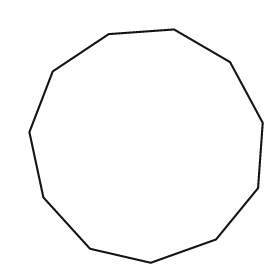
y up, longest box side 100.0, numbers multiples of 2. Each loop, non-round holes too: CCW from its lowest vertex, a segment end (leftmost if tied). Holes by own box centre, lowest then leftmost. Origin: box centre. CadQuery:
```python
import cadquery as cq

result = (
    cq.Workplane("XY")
    .moveTo(2.0, -50.0)
    .lineTo(30.0, -40.0)
    .lineTo(48.0, -18.0)
    .lineTo(50.0, 10.0)
    .lineTo(36.0, 36.0)
    .lineTo(12.0, 50.0)
    .lineTo(-16.0, 48.0)
    .lineTo(-40.0, 32.0)
    .lineTo(-50.0, 6.0)
    .lineTo(-44.0, -22.0)
    .lineTo(-24.0, -44.0)
    .close()
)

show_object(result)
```